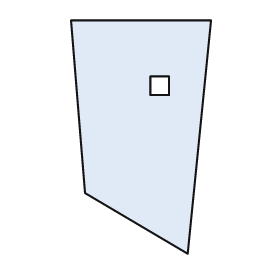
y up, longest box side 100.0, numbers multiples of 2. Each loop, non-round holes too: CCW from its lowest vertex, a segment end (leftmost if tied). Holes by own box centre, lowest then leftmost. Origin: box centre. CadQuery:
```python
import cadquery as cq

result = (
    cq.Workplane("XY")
    .moveTo(20.0, -50.0)
    .lineTo(30.0, 50.0)
    .lineTo(-30.0, 50.0)
    .lineTo(-24.0, -24.0)
    .close()
    .moveTo(4.0, 18.0)
    .lineTo(12.0, 18.0)
    .lineTo(12.0, 26.0)
    .lineTo(4.0, 26.0)
    .close()
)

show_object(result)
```